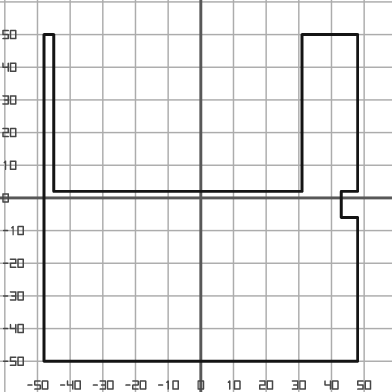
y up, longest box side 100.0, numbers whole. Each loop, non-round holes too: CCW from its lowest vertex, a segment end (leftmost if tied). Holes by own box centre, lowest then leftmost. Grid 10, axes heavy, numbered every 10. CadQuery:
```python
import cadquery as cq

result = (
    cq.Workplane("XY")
    .moveTo(-48.0, -50.0)
    .lineTo(48.0, -50.0)
    .lineTo(48.0, -6.0)
    .lineTo(43.0, -6.0)
    .lineTo(43.0, 2.0)
    .lineTo(48.0, 2.0)
    .lineTo(48.0, 50.0)
    .lineTo(31.0, 50.0)
    .lineTo(31.0, 2.0)
    .lineTo(-45.0, 2.0)
    .lineTo(-45.0, 50.0)
    .lineTo(-48.0, 50.0)
    .close()
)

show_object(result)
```